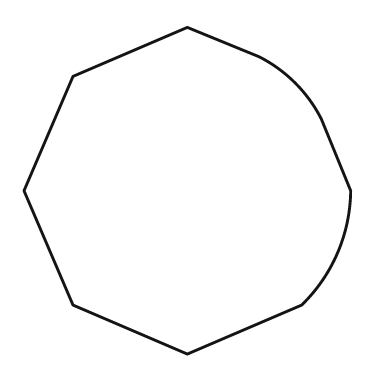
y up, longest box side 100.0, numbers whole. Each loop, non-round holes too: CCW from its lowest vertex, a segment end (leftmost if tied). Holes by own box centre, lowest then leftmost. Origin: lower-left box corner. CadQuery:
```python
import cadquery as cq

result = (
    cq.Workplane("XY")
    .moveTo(50.0, 0.0)
    .lineTo(85.0, 15.0)
    .threePointArc((96.0, 31.0), (100.0, 50.0))
    .lineTo(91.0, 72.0)
    .threePointArc((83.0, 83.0), (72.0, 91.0))
    .lineTo(50.0, 100.0)
    .lineTo(15.0, 85.0)
    .lineTo(0.0, 50.0)
    .lineTo(15.0, 15.0)
    .close()
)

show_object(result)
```